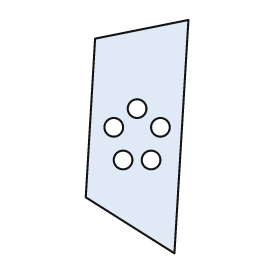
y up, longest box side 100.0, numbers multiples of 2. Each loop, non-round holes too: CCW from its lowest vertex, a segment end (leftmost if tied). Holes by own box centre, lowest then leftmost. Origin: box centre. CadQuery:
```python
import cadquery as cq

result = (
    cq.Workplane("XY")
    .moveTo(16.0, -50.0)
    .lineTo(22.0, 50.0)
    .lineTo(-18.0, 42.0)
    .lineTo(-22.0, -26.0)
    .close()
    .moveTo(-6.0, -10.0)
    .circle(4.0)
    .moveTo(6.0, -10.0)
    .circle(4.0)
    .moveTo(-10.0, 4.0)
    .circle(4.0)
    .moveTo(10.0, 4.0)
    .circle(4.0)
    .moveTo(0.0, 12.0)
    .circle(4.0)
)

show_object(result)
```